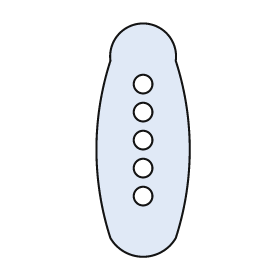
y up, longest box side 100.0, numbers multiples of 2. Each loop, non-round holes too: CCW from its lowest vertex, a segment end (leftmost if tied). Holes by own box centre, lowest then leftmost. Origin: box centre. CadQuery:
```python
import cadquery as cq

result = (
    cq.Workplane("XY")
    .moveTo(-14.0, -42.0)
    .threePointArc((0.0, -50.0), (14.0, -42.0))
    .threePointArc((20.0, -4.0), (14.0, 34.0))
    .threePointArc((0.0, 50.0), (-14.0, 34.0))
    .threePointArc((-20.0, -4.0), (-14.0, -42.0))
    .close()
    .moveTo(0.0, -24.0)
    .circle(4.0)
    .moveTo(0.0, -12.0)
    .circle(4.0)
    .moveTo(0.0, 0.0)
    .circle(4.0)
    .moveTo(0.0, 12.0)
    .circle(4.0)
    .moveTo(0.0, 24.0)
    .circle(4.0)
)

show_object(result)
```